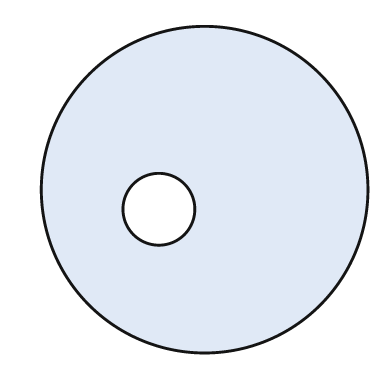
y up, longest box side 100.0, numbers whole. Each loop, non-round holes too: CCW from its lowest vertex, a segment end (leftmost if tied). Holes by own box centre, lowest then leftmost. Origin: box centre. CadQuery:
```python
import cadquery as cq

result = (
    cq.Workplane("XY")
    .moveTo(0.0, 0.0)
    .circle(50.0)
    .moveTo(-14.0, -6.0)
    .circle(11.0)
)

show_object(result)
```